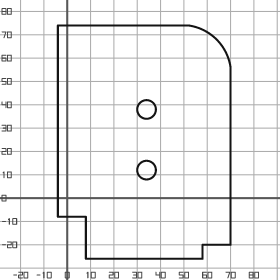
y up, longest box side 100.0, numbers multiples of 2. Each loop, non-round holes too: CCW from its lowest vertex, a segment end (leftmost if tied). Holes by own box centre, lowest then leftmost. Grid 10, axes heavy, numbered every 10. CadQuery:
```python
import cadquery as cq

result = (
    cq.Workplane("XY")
    .moveTo(8.0, -26.0)
    .lineTo(58.0, -26.0)
    .lineTo(58.0, -20.0)
    .lineTo(70.0, -20.0)
    .lineTo(70.0, 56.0)
    .threePointArc((64.0, 68.0), (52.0, 74.0))
    .lineTo(-4.0, 74.0)
    .lineTo(-4.0, -8.0)
    .lineTo(8.0, -8.0)
    .close()
    .moveTo(34.0, 12.0)
    .circle(4.0)
    .moveTo(34.0, 38.0)
    .circle(4.0)
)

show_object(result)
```